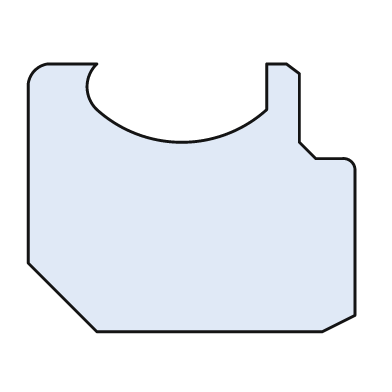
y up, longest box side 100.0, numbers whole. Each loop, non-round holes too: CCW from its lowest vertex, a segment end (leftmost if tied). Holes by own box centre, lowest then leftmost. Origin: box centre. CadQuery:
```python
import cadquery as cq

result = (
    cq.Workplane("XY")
    .moveTo(-29.0, -41.0)
    .lineTo(40.0, -41.0)
    .lineTo(50.0, -36.0)
    .lineTo(50.0, 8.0)
    .threePointArc((49.0, 11.0), (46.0, 12.0))
    .lineTo(38.0, 12.0)
    .lineTo(33.0, 17.0)
    .lineTo(33.0, 38.0)
    .lineTo(29.0, 41.0)
    .lineTo(23.0, 41.0)
    .lineTo(23.0, 27.0)
    .threePointArc((-3.0, 17.0), (-29.0, 27.0))
    .threePointArc((-32.0, 34.0), (-29.0, 41.0))
    .lineTo(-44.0, 41.0)
    .threePointArc((-48.0, 39.0), (-50.0, 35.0))
    .lineTo(-50.0, -20.0)
    .close()
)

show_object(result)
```